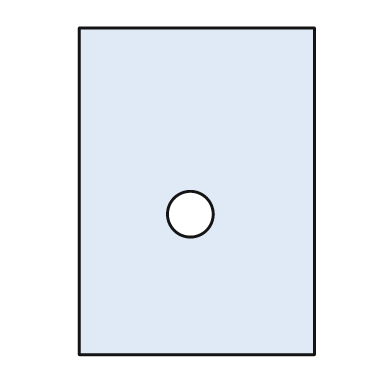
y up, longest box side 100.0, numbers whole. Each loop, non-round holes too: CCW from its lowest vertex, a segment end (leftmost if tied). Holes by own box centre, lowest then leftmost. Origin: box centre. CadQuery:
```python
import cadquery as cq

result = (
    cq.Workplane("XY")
    .moveTo(-36.0, -50.0)
    .lineTo(36.0, -50.0)
    .lineTo(36.0, 50.0)
    .lineTo(-36.0, 50.0)
    .close()
    .moveTo(-2.0, -7.0)
    .circle(7.0)
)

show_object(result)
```